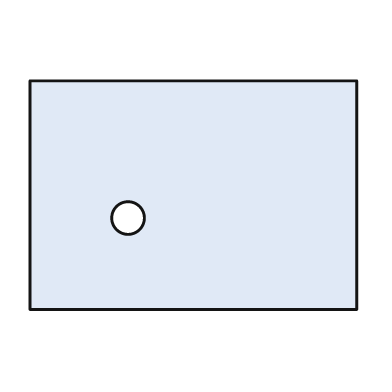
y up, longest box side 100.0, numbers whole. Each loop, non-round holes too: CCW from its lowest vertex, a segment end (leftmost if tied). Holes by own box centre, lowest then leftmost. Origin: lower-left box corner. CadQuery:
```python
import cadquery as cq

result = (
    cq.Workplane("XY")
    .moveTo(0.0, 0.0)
    .lineTo(100.0, 0.0)
    .lineTo(100.0, 70.0)
    .lineTo(0.0, 70.0)
    .close()
    .moveTo(30.0, 28.0)
    .circle(5.0)
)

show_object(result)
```